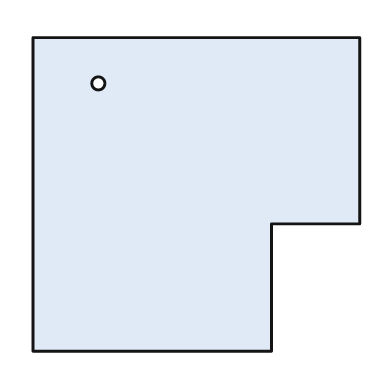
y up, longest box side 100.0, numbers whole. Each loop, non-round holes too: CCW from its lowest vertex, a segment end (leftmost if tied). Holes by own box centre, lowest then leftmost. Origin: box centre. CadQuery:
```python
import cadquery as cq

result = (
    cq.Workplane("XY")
    .moveTo(-50.0, -48.0)
    .lineTo(23.0, -48.0)
    .lineTo(23.0, -9.0)
    .lineTo(50.0, -9.0)
    .lineTo(50.0, 48.0)
    .lineTo(-50.0, 48.0)
    .close()
    .moveTo(-30.0, 34.0)
    .circle(2.0)
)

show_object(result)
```